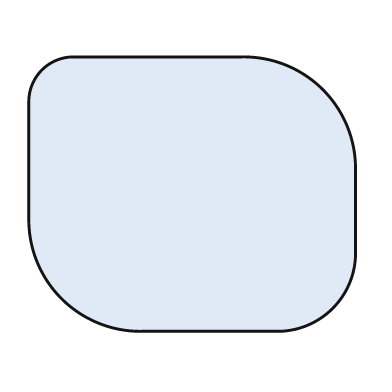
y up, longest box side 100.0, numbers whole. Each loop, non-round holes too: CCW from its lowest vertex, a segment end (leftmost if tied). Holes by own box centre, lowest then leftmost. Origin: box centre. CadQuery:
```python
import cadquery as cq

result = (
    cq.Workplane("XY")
    .moveTo(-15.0, -42.0)
    .lineTo(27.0, -42.0)
    .threePointArc((43.0, -35.0), (50.0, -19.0))
    .lineTo(50.0, 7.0)
    .threePointArc((40.0, 32.0), (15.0, 42.0))
    .lineTo(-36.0, 42.0)
    .threePointArc((-46.0, 38.0), (-50.0, 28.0))
    .lineTo(-50.0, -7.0)
    .threePointArc((-40.0, -32.0), (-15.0, -42.0))
    .close()
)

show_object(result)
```